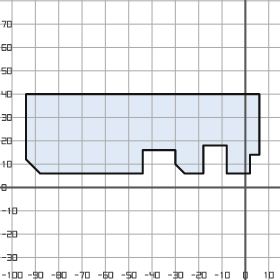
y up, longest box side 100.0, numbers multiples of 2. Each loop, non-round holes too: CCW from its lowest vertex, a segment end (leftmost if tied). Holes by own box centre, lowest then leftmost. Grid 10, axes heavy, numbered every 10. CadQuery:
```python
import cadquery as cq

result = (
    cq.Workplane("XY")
    .moveTo(-88.0, 6.0)
    .lineTo(-44.0, 6.0)
    .lineTo(-44.0, 16.0)
    .lineTo(-30.0, 16.0)
    .lineTo(-30.0, 10.0)
    .lineTo(-26.0, 6.0)
    .lineTo(-18.0, 6.0)
    .lineTo(-18.0, 18.0)
    .lineTo(-8.0, 18.0)
    .lineTo(-8.0, 6.0)
    .lineTo(2.0, 6.0)
    .lineTo(2.0, 14.0)
    .lineTo(6.0, 14.0)
    .lineTo(6.0, 40.0)
    .lineTo(-94.0, 40.0)
    .lineTo(-94.0, 12.0)
    .close()
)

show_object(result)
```